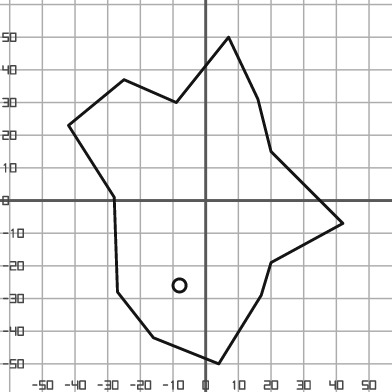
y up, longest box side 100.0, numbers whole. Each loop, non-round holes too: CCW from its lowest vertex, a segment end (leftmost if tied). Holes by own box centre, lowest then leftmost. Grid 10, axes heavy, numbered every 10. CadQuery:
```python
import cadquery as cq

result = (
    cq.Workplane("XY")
    .moveTo(4.0, -50.0)
    .lineTo(17.0, -29.0)
    .lineTo(20.0, -19.0)
    .lineTo(42.0, -7.0)
    .lineTo(20.0, 15.0)
    .lineTo(16.0, 31.0)
    .lineTo(7.0, 50.0)
    .lineTo(-9.0, 30.0)
    .lineTo(-25.0, 37.0)
    .lineTo(-42.0, 23.0)
    .lineTo(-28.0, 1.0)
    .lineTo(-27.0, -28.0)
    .lineTo(-16.0, -42.0)
    .close()
    .moveTo(-8.0, -26.0)
    .circle(2.0)
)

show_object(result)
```